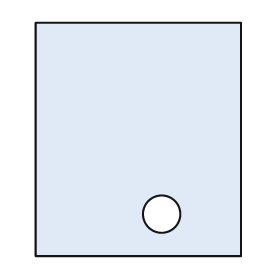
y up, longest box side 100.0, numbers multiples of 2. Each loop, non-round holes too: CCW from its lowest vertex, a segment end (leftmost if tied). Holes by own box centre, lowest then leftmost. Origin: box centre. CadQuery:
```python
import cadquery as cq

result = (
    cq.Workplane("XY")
    .moveTo(-44.0, -50.0)
    .lineTo(44.0, -50.0)
    .lineTo(44.0, 50.0)
    .lineTo(-44.0, 50.0)
    .close()
    .moveTo(10.0, -32.0)
    .circle(8.0)
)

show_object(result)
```